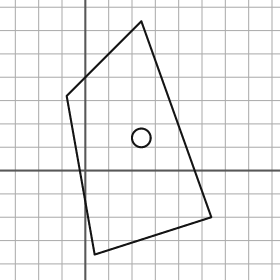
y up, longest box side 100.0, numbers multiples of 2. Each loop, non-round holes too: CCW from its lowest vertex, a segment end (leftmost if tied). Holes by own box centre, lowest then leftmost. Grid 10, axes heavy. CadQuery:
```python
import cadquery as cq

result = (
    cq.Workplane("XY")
    .moveTo(4.0, -36.0)
    .lineTo(54.0, -20.0)
    .lineTo(24.0, 64.0)
    .lineTo(-8.0, 32.0)
    .close()
    .moveTo(24.0, 14.0)
    .circle(4.0)
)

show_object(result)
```